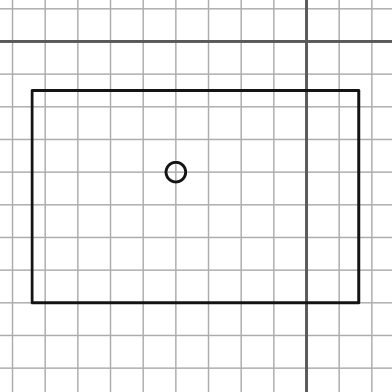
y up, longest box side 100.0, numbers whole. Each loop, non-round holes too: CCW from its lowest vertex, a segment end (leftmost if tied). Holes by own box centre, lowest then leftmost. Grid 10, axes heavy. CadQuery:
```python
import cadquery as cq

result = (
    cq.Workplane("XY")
    .moveTo(-84.0, -80.0)
    .lineTo(16.0, -80.0)
    .lineTo(16.0, -15.0)
    .lineTo(-84.0, -15.0)
    .close()
    .moveTo(-40.0, -40.0)
    .circle(3.0)
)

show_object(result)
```